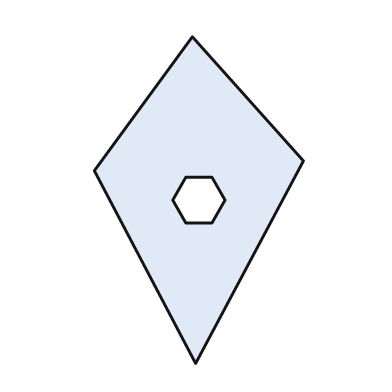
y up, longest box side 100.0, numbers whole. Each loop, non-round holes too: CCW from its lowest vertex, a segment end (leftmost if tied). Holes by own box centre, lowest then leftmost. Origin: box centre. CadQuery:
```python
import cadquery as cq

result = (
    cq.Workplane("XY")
    .moveTo(-1.0, -50.0)
    .lineTo(32.0, 12.0)
    .lineTo(-2.0, 50.0)
    .lineTo(-32.0, 9.0)
    .close()
    .moveTo(-4.0, -7.0)
    .lineTo(4.0, -7.0)
    .lineTo(8.0, 0.0)
    .lineTo(4.0, 7.0)
    .lineTo(-4.0, 7.0)
    .lineTo(-8.0, 0.0)
    .close()
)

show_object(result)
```